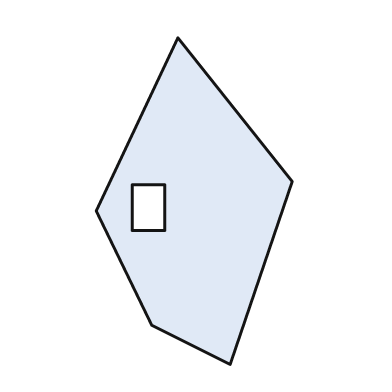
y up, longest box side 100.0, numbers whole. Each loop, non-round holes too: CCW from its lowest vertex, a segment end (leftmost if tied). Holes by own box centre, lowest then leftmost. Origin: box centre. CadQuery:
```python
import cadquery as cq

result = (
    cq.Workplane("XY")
    .moveTo(11.0, -50.0)
    .lineTo(30.0, 6.0)
    .lineTo(-5.0, 50.0)
    .lineTo(-30.0, -3.0)
    .lineTo(-13.0, -38.0)
    .close()
    .moveTo(-19.0, -9.0)
    .lineTo(-9.0, -9.0)
    .lineTo(-9.0, 5.0)
    .lineTo(-19.0, 5.0)
    .close()
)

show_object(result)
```